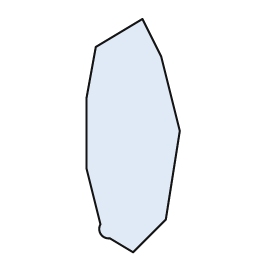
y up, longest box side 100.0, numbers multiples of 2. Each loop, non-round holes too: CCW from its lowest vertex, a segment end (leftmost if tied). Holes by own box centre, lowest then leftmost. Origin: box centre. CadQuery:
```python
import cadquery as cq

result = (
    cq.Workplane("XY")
    .moveTo(0.0, -50.0)
    .lineTo(14.0, -36.0)
    .lineTo(20.0, 2.0)
    .lineTo(12.0, 34.0)
    .lineTo(4.0, 50.0)
    .lineTo(-16.0, 38.0)
    .lineTo(-20.0, 16.0)
    .lineTo(-20.0, -14.0)
    .lineTo(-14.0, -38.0)
    .threePointArc((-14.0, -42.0), (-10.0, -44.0))
    .close()
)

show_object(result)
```